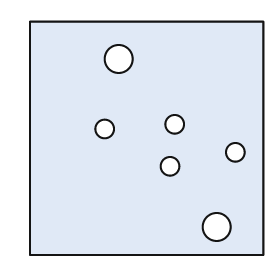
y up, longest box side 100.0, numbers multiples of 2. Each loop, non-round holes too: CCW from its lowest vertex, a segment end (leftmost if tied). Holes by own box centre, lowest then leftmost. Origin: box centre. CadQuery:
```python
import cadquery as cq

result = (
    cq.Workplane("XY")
    .moveTo(-50.0, -50.0)
    .lineTo(50.0, -50.0)
    .lineTo(50.0, 50.0)
    .lineTo(-50.0, 50.0)
    .close()
    .moveTo(30.0, -38.0)
    .circle(6.0)
    .moveTo(10.0, -12.0)
    .circle(4.0)
    .moveTo(38.0, -6.0)
    .circle(4.0)
    .moveTo(-18.0, 4.0)
    .circle(4.0)
    .moveTo(12.0, 6.0)
    .circle(4.0)
    .moveTo(-12.0, 34.0)
    .circle(6.0)
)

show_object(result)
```